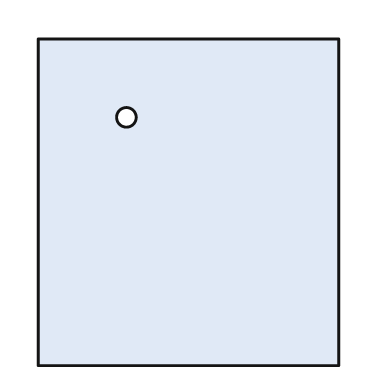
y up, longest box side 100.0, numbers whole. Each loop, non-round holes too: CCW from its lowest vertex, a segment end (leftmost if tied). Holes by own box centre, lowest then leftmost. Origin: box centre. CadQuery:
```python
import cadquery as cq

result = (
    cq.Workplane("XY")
    .moveTo(-46.0, -50.0)
    .lineTo(46.0, -50.0)
    .lineTo(46.0, 50.0)
    .lineTo(-46.0, 50.0)
    .close()
    .moveTo(-19.0, 26.0)
    .circle(3.0)
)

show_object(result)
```